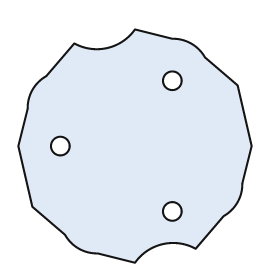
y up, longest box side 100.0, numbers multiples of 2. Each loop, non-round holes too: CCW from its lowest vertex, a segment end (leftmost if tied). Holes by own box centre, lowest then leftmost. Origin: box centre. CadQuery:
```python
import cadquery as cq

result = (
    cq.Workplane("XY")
    .moveTo(0.0, -50.0)
    .threePointArc((12.0, -42.0), (26.0, -44.0))
    .lineTo(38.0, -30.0)
    .threePointArc((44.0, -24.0), (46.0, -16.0))
    .lineTo(50.0, 0.0)
    .lineTo(44.0, 26.0)
    .lineTo(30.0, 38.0)
    .threePointArc((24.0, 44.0), (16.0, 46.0))
    .lineTo(0.0, 50.0)
    .threePointArc((-12.0, 42.0), (-26.0, 44.0))
    .lineTo(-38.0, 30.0)
    .threePointArc((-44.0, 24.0), (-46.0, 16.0))
    .lineTo(-50.0, 0.0)
    .lineTo(-44.0, -26.0)
    .lineTo(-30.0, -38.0)
    .threePointArc((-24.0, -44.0), (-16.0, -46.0))
    .close()
    .moveTo(16.0, -28.0)
    .circle(4.0)
    .moveTo(-32.0, 0.0)
    .circle(4.0)
    .moveTo(16.0, 28.0)
    .circle(4.0)
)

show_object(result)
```